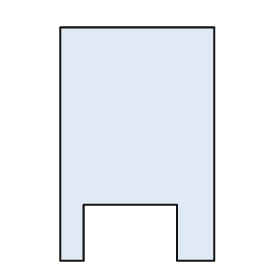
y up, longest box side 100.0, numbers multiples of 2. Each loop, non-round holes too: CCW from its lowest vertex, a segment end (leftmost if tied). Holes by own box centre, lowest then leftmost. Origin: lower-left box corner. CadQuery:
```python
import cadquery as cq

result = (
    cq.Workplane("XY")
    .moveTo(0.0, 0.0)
    .lineTo(10.0, 0.0)
    .lineTo(10.0, 24.0)
    .lineTo(50.0, 24.0)
    .lineTo(50.0, 0.0)
    .lineTo(66.0, 0.0)
    .lineTo(66.0, 100.0)
    .lineTo(0.0, 100.0)
    .close()
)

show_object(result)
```